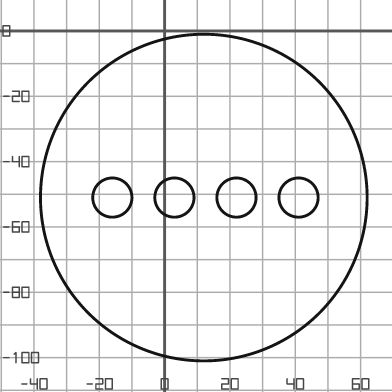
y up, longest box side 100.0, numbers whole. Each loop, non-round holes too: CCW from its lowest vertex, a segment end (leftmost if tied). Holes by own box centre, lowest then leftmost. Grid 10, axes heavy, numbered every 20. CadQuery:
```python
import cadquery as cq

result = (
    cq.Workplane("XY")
    .moveTo(12.0, -51.0)
    .circle(50.0)
    .moveTo(-16.0, -51.0)
    .circle(6.0)
    .moveTo(3.0, -51.0)
    .circle(6.0)
    .moveTo(22.0, -51.0)
    .circle(6.0)
    .moveTo(41.0, -51.0)
    .circle(6.0)
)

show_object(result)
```